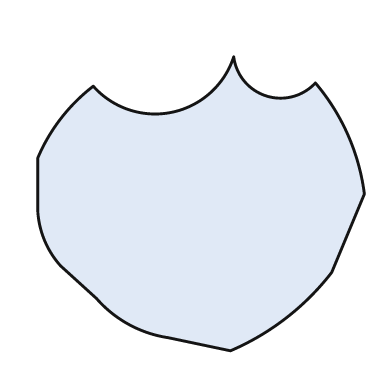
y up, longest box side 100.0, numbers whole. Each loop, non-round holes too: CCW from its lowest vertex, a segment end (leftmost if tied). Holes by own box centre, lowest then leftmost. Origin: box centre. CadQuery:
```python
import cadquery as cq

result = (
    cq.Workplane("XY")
    .moveTo(9.0, -45.0)
    .threePointArc((26.0, -35.0), (40.0, -21.0))
    .lineTo(50.0, 3.0)
    .threePointArc((45.0, 21.0), (35.0, 37.0))
    .threePointArc((20.0, 33.0), (10.0, 45.0))
    .threePointArc((-9.0, 28.0), (-33.0, 36.0))
    .threePointArc((-43.0, 26.0), (-50.0, 14.0))
    .lineTo(-50.0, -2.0)
    .threePointArc((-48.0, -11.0), (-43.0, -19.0))
    .lineTo(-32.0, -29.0)
    .threePointArc((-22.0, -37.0), (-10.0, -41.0))
    .close()
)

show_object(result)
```